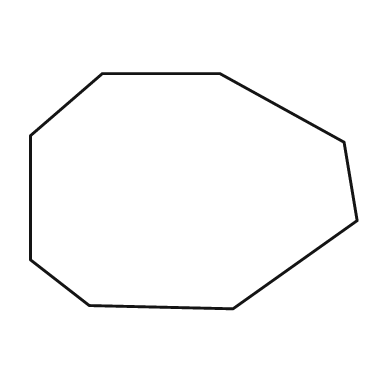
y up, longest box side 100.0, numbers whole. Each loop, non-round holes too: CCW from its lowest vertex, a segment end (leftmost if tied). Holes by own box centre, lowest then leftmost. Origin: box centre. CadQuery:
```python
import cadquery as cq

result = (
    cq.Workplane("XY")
    .moveTo(12.0, -36.0)
    .lineTo(50.0, -9.0)
    .lineTo(46.0, 15.0)
    .lineTo(8.0, 36.0)
    .lineTo(-28.0, 36.0)
    .lineTo(-50.0, 17.0)
    .lineTo(-50.0, -21.0)
    .lineTo(-32.0, -35.0)
    .close()
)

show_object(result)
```